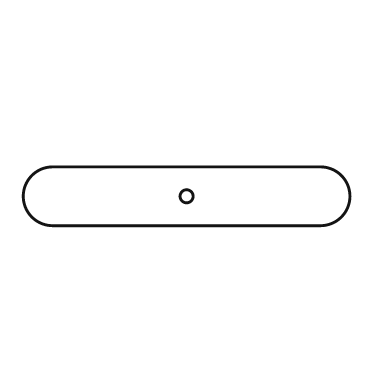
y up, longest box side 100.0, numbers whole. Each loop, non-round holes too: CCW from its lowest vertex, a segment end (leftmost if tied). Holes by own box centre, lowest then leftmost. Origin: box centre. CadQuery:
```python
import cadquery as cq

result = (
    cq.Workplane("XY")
    .moveTo(-41.0, -9.0)
    .lineTo(41.0, -9.0)
    .threePointArc((50.0, 0.0), (41.0, 9.0))
    .lineTo(-41.0, 9.0)
    .threePointArc((-50.0, 0.0), (-41.0, -9.0))
    .close()
    .moveTo(0.0, 0.0)
    .circle(2.0)
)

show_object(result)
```